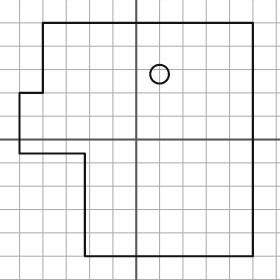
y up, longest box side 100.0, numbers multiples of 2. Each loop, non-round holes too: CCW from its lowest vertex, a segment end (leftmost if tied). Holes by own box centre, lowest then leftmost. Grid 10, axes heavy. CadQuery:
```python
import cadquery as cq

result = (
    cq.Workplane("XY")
    .moveTo(-22.0, -50.0)
    .lineTo(50.0, -50.0)
    .lineTo(50.0, 50.0)
    .lineTo(-40.0, 50.0)
    .lineTo(-40.0, 20.0)
    .lineTo(-50.0, 20.0)
    .lineTo(-50.0, -6.0)
    .lineTo(-22.0, -6.0)
    .close()
    .moveTo(10.0, 28.0)
    .circle(4.0)
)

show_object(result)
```